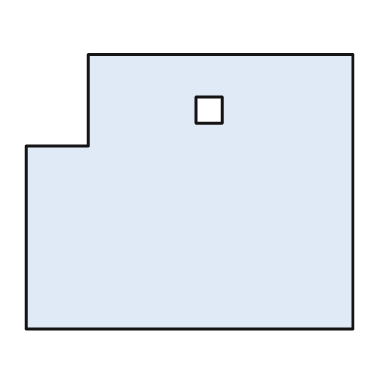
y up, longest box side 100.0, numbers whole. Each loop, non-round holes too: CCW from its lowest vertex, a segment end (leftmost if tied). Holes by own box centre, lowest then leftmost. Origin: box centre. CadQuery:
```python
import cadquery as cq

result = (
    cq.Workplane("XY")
    .moveTo(-50.0, -42.0)
    .lineTo(50.0, -42.0)
    .lineTo(50.0, 42.0)
    .lineTo(-31.0, 42.0)
    .lineTo(-31.0, 14.0)
    .lineTo(-50.0, 14.0)
    .close()
    .moveTo(2.0, 21.0)
    .lineTo(10.0, 21.0)
    .lineTo(10.0, 29.0)
    .lineTo(2.0, 29.0)
    .close()
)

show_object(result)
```